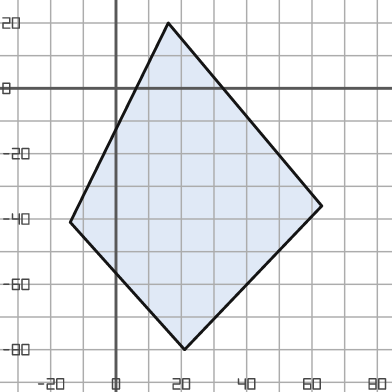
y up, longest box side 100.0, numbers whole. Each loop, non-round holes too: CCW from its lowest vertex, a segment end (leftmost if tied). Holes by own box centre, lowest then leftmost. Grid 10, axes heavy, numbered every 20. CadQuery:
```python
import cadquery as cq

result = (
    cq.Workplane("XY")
    .moveTo(21.0, -80.0)
    .lineTo(63.0, -36.0)
    .lineTo(16.0, 20.0)
    .lineTo(-14.0, -41.0)
    .close()
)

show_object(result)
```